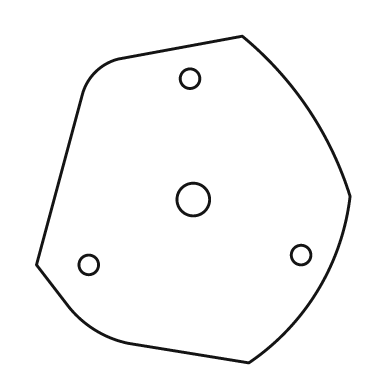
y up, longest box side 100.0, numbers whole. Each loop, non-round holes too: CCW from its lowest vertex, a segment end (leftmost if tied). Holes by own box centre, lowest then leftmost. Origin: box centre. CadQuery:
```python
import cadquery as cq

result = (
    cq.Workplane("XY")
    .moveTo(17.0, -50.0)
    .threePointArc((38.0, -28.0), (48.0, 1.0))
    .threePointArc((35.0, 28.0), (15.0, 50.0))
    .lineTo(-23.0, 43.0)
    .threePointArc((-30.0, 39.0), (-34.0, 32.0))
    .lineTo(-48.0, -20.0)
    .lineTo(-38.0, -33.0)
    .threePointArc((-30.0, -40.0), (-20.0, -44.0))
    .close()
    .moveTo(-32.0, -20.0)
    .circle(3.0)
    .moveTo(33.0, -17.0)
    .circle(3.0)
    .moveTo(0.0, 0.0)
    .circle(5.0)
    .moveTo(-1.0, 37.0)
    .circle(3.0)
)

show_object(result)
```